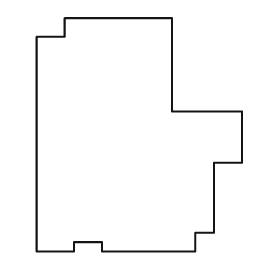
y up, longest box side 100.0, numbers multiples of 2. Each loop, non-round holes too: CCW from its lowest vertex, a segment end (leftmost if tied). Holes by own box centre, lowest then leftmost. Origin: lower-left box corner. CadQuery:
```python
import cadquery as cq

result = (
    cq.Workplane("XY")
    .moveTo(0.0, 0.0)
    .lineTo(16.0, 0.0)
    .lineTo(16.0, 4.0)
    .lineTo(28.0, 4.0)
    .lineTo(28.0, 0.0)
    .lineTo(68.0, 0.0)
    .lineTo(68.0, 8.0)
    .lineTo(76.0, 8.0)
    .lineTo(76.0, 38.0)
    .lineTo(88.0, 38.0)
    .lineTo(88.0, 60.0)
    .lineTo(58.0, 60.0)
    .lineTo(58.0, 100.0)
    .lineTo(12.0, 100.0)
    .lineTo(12.0, 92.0)
    .lineTo(0.0, 92.0)
    .close()
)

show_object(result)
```